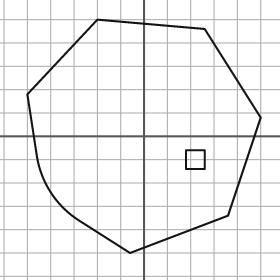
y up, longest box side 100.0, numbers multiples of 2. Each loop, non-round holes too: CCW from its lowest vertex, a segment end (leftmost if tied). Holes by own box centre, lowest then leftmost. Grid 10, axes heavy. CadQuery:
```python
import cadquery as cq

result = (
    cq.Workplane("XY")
    .moveTo(-6.0, -50.0)
    .lineTo(36.0, -34.0)
    .lineTo(50.0, 8.0)
    .lineTo(26.0, 46.0)
    .lineTo(-20.0, 50.0)
    .lineTo(-50.0, 18.0)
    .lineTo(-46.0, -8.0)
    .threePointArc((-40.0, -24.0), (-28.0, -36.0))
    .close()
    .moveTo(18.0, -14.0)
    .lineTo(26.0, -14.0)
    .lineTo(26.0, -6.0)
    .lineTo(18.0, -6.0)
    .close()
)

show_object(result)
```